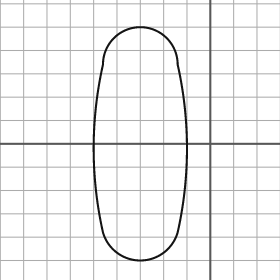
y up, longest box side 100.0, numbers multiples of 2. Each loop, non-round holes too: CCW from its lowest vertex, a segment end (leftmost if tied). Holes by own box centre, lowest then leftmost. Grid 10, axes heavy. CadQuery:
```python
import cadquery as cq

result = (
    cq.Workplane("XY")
    .moveTo(-46.0, -38.0)
    .threePointArc((-30.0, -50.0), (-14.0, -38.0))
    .threePointArc((-10.0, -2.0), (-14.0, 34.0))
    .threePointArc((-30.0, 50.0), (-46.0, 34.0))
    .threePointArc((-50.0, -2.0), (-46.0, -38.0))
    .close()
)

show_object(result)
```